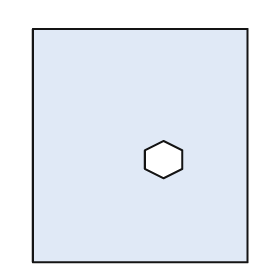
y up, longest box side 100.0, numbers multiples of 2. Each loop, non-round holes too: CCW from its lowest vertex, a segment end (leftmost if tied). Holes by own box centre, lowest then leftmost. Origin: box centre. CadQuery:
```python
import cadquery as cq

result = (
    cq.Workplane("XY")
    .moveTo(-46.0, -50.0)
    .lineTo(46.0, -50.0)
    .lineTo(46.0, 50.0)
    .lineTo(-46.0, 50.0)
    .close()
    .moveTo(10.0, -14.0)
    .lineTo(18.0, -10.0)
    .lineTo(18.0, -2.0)
    .lineTo(10.0, 2.0)
    .lineTo(2.0, -2.0)
    .lineTo(2.0, -10.0)
    .close()
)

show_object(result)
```